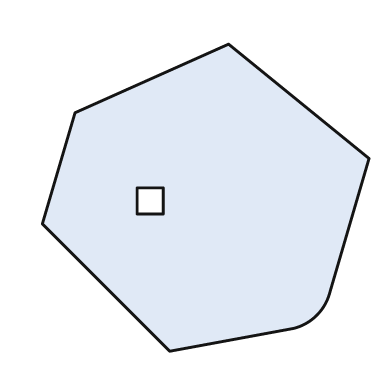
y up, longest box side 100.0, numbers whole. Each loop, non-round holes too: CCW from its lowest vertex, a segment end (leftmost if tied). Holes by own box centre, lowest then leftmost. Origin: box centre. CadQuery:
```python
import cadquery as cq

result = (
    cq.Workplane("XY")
    .moveTo(-11.0, -47.0)
    .lineTo(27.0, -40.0)
    .threePointArc((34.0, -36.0), (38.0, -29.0))
    .lineTo(50.0, 12.0)
    .lineTo(7.0, 47.0)
    .lineTo(-40.0, 26.0)
    .lineTo(-50.0, -8.0)
    .close()
    .moveTo(-21.0, -5.0)
    .lineTo(-13.0, -5.0)
    .lineTo(-13.0, 3.0)
    .lineTo(-21.0, 3.0)
    .close()
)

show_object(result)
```